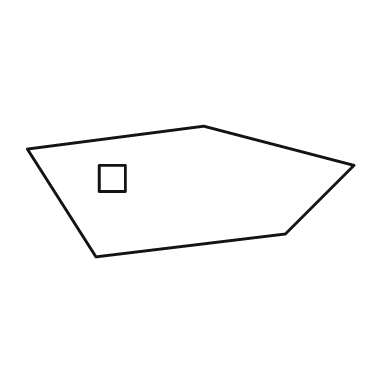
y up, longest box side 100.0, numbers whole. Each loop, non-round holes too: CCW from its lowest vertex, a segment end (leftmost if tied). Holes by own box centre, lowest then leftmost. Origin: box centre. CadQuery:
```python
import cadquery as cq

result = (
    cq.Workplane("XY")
    .moveTo(-29.0, -20.0)
    .lineTo(29.0, -13.0)
    .lineTo(50.0, 8.0)
    .lineTo(4.0, 20.0)
    .lineTo(-50.0, 13.0)
    .close()
    .moveTo(-28.0, 0.0)
    .lineTo(-20.0, 0.0)
    .lineTo(-20.0, 8.0)
    .lineTo(-28.0, 8.0)
    .close()
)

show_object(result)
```